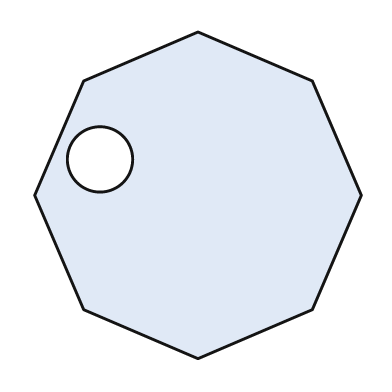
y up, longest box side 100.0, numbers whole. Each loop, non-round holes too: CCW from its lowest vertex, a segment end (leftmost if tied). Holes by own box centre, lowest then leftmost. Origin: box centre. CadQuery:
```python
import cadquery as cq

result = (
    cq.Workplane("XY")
    .moveTo(0.0, -50.0)
    .lineTo(35.0, -35.0)
    .lineTo(50.0, 0.0)
    .lineTo(35.0, 35.0)
    .lineTo(0.0, 50.0)
    .lineTo(-35.0, 35.0)
    .lineTo(-50.0, 0.0)
    .lineTo(-35.0, -35.0)
    .close()
    .moveTo(-30.0, 11.0)
    .circle(10.0)
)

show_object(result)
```